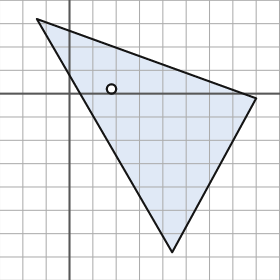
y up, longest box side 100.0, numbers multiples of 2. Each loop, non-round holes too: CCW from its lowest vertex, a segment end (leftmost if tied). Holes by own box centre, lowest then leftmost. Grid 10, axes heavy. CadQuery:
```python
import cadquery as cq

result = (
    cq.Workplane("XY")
    .moveTo(44.0, -68.0)
    .lineTo(80.0, -2.0)
    .lineTo(-14.0, 32.0)
    .close()
    .moveTo(18.0, 2.0)
    .circle(2.0)
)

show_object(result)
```